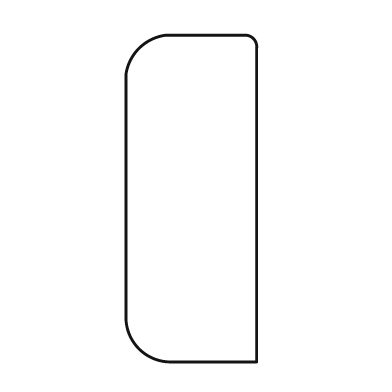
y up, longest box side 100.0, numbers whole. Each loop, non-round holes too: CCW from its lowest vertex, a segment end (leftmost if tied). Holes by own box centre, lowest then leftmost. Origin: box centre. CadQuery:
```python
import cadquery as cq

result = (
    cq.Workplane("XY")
    .moveTo(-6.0, -50.0)
    .lineTo(20.0, -50.0)
    .lineTo(20.0, 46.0)
    .threePointArc((19.0, 49.0), (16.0, 50.0))
    .lineTo(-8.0, 50.0)
    .threePointArc((-16.0, 46.0), (-20.0, 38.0))
    .lineTo(-20.0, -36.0)
    .threePointArc((-16.0, -46.0), (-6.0, -50.0))
    .close()
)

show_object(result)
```